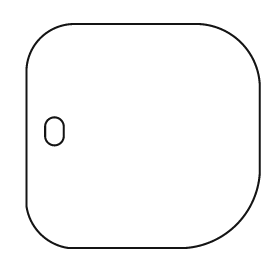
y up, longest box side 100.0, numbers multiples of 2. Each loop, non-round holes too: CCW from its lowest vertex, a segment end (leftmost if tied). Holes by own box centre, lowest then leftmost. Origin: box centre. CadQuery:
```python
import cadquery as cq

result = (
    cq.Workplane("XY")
    .moveTo(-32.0, -48.0)
    .lineTo(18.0, -48.0)
    .threePointArc((40.0, -38.0), (50.0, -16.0))
    .lineTo(50.0, 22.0)
    .threePointArc((42.0, 40.0), (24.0, 48.0))
    .lineTo(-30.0, 48.0)
    .threePointArc((-44.0, 42.0), (-50.0, 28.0))
    .lineTo(-50.0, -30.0)
    .threePointArc((-44.0, -42.0), (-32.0, -48.0))
    .close()
    .moveTo(-42.0, 0.0)
    .threePointArc((-38.0, -4.0), (-34.0, 0.0))
    .lineTo(-34.0, 4.0)
    .threePointArc((-38.0, 8.0), (-42.0, 4.0))
    .close()
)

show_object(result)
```